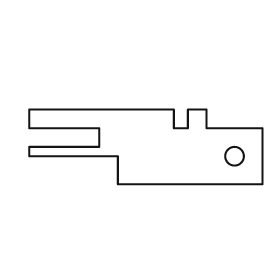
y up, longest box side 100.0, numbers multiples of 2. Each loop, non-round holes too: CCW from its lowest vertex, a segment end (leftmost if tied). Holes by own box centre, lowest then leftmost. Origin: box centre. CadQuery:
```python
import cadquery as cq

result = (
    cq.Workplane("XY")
    .moveTo(-12.0, -16.0)
    .lineTo(50.0, -16.0)
    .lineTo(50.0, 8.0)
    .lineTo(26.0, 8.0)
    .lineTo(26.0, 16.0)
    .lineTo(18.0, 16.0)
    .lineTo(18.0, 8.0)
    .lineTo(12.0, 8.0)
    .lineTo(12.0, 16.0)
    .lineTo(-50.0, 16.0)
    .lineTo(-50.0, 8.0)
    .lineTo(-20.0, 8.0)
    .lineTo(-20.0, 0.0)
    .lineTo(-50.0, 0.0)
    .lineTo(-50.0, -4.0)
    .lineTo(-12.0, -4.0)
    .close()
    .moveTo(38.0, -4.0)
    .circle(4.0)
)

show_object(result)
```